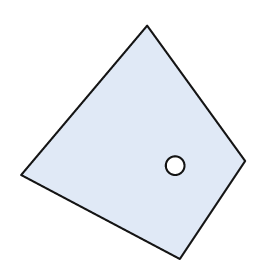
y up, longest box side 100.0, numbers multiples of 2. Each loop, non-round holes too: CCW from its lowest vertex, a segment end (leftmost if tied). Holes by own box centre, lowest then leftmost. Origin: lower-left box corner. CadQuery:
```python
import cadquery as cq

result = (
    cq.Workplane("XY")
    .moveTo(68.0, 0.0)
    .lineTo(96.0, 42.0)
    .lineTo(54.0, 100.0)
    .lineTo(0.0, 36.0)
    .close()
    .moveTo(66.0, 40.0)
    .circle(4.0)
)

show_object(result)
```